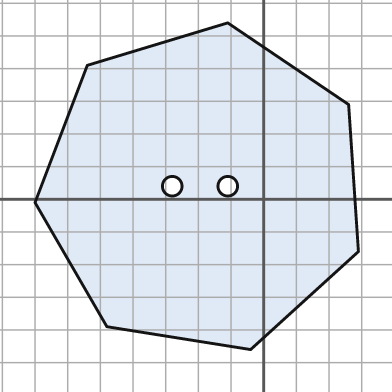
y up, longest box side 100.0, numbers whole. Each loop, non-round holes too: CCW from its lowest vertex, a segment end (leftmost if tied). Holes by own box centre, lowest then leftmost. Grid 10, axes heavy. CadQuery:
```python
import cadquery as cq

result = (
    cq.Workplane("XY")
    .moveTo(-4.0, -46.0)
    .lineTo(29.0, -16.0)
    .lineTo(26.0, 29.0)
    .lineTo(-11.0, 54.0)
    .lineTo(-54.0, 41.0)
    .lineTo(-70.0, -1.0)
    .lineTo(-48.0, -39.0)
    .close()
    .moveTo(-28.0, 4.0)
    .circle(3.0)
    .moveTo(-11.0, 4.0)
    .circle(3.0)
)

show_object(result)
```